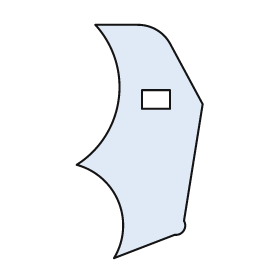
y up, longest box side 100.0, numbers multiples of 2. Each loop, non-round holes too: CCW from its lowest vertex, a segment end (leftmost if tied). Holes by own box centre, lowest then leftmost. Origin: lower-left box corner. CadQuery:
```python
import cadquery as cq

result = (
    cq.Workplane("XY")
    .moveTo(16.0, 0.0)
    .lineTo(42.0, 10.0)
    .threePointArc((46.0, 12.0), (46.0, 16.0))
    .lineTo(54.0, 66.0)
    .lineTo(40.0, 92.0)
    .threePointArc((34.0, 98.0), (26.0, 100.0))
    .lineTo(8.0, 100.0)
    .threePointArc((18.0, 68.0), (0.0, 40.0))
    .threePointArc((18.0, 24.0), (16.0, 0.0))
    .close()
    .moveTo(28.0, 64.0)
    .lineTo(40.0, 64.0)
    .lineTo(40.0, 72.0)
    .lineTo(28.0, 72.0)
    .close()
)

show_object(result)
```